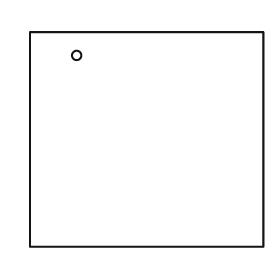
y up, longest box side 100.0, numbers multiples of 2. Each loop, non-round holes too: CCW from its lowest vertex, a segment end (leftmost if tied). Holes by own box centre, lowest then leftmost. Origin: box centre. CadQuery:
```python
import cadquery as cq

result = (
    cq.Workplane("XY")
    .moveTo(-50.0, -46.0)
    .lineTo(50.0, -46.0)
    .lineTo(50.0, 46.0)
    .lineTo(-50.0, 46.0)
    .close()
    .moveTo(-30.0, 36.0)
    .circle(2.0)
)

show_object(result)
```